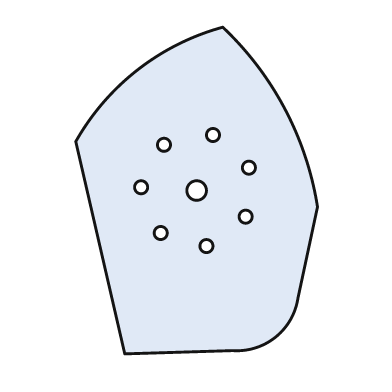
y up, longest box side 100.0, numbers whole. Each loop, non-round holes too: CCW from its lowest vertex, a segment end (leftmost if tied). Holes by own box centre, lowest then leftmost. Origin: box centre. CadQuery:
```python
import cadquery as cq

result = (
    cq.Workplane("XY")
    .moveTo(-22.0, -50.0)
    .lineTo(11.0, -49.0)
    .threePointArc((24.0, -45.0), (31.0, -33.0))
    .lineTo(37.0, -5.0)
    .threePointArc((27.0, 25.0), (8.0, 50.0))
    .threePointArc((-18.0, 37.0), (-37.0, 15.0))
    .close()
    .moveTo(3.0, -17.0)
    .circle(2.0)
    .moveTo(-11.0, -13.0)
    .circle(2.0)
    .moveTo(15.0, -8.0)
    .circle(2.0)
    .moveTo(0.0, 0.0)
    .circle(3.0)
    .moveTo(-17.0, 1.0)
    .circle(2.0)
    .moveTo(16.0, 7.0)
    .circle(2.0)
    .moveTo(-10.0, 14.0)
    .circle(2.0)
    .moveTo(5.0, 17.0)
    .circle(2.0)
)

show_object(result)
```